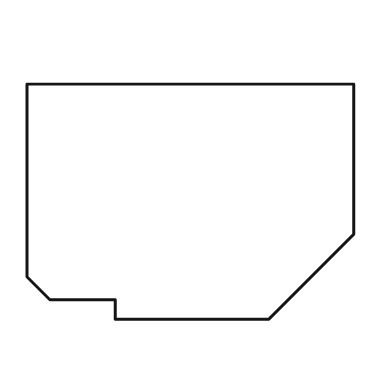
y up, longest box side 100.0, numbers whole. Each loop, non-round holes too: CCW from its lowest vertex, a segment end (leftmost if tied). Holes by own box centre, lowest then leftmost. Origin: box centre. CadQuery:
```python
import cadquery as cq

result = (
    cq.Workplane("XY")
    .moveTo(-23.0, -36.0)
    .lineTo(24.0, -36.0)
    .lineTo(50.0, -10.0)
    .lineTo(50.0, 36.0)
    .lineTo(-50.0, 36.0)
    .lineTo(-50.0, -23.0)
    .lineTo(-43.0, -30.0)
    .lineTo(-23.0, -30.0)
    .close()
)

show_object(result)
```